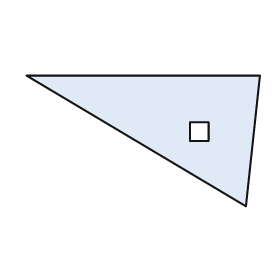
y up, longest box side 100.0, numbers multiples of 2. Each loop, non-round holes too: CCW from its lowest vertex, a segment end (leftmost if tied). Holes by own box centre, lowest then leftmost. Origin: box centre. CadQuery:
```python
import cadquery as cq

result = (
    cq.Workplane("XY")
    .moveTo(44.0, -28.0)
    .lineTo(50.0, 28.0)
    .lineTo(-50.0, 28.0)
    .close()
    .moveTo(20.0, 0.0)
    .lineTo(28.0, 0.0)
    .lineTo(28.0, 8.0)
    .lineTo(20.0, 8.0)
    .close()
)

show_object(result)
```